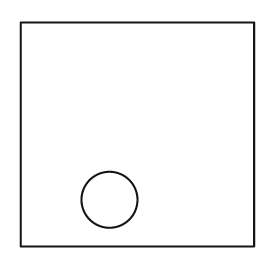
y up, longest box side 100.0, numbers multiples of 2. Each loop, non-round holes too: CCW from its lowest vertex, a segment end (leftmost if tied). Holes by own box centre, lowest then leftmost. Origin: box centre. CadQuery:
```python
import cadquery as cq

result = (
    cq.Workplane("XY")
    .moveTo(-50.0, -48.0)
    .lineTo(50.0, -48.0)
    .lineTo(50.0, 48.0)
    .lineTo(-50.0, 48.0)
    .close()
    .moveTo(-12.0, -28.0)
    .circle(12.0)
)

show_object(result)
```